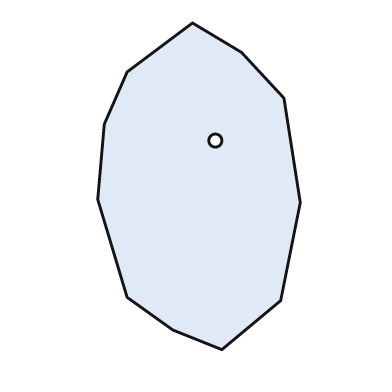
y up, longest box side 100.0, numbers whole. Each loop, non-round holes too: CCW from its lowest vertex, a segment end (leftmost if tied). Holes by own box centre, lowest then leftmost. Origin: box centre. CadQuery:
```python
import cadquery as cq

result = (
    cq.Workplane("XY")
    .moveTo(7.0, -50.0)
    .lineTo(25.0, -35.0)
    .lineTo(31.0, -5.0)
    .lineTo(26.0, 27.0)
    .lineTo(13.0, 41.0)
    .lineTo(-2.0, 50.0)
    .lineTo(-22.0, 35.0)
    .lineTo(-29.0, 19.0)
    .lineTo(-31.0, -4.0)
    .lineTo(-22.0, -34.0)
    .lineTo(-8.0, -44.0)
    .close()
    .moveTo(5.0, 14.0)
    .circle(2.0)
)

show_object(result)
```